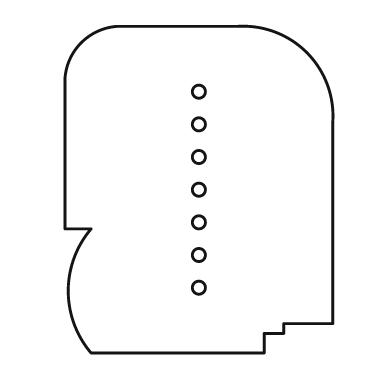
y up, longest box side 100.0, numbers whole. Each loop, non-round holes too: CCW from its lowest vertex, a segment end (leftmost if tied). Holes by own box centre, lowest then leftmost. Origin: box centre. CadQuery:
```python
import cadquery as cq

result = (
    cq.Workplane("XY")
    .moveTo(-33.0, -50.0)
    .lineTo(20.0, -50.0)
    .lineTo(20.0, -44.0)
    .lineTo(26.0, -44.0)
    .lineTo(26.0, -41.0)
    .lineTo(41.0, -41.0)
    .lineTo(41.0, 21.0)
    .threePointArc((33.0, 42.0), (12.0, 50.0))
    .lineTo(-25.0, 50.0)
    .threePointArc((-36.0, 45.0), (-41.0, 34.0))
    .lineTo(-41.0, -12.0)
    .lineTo(-33.0, -12.0)
    .threePointArc((-40.0, -31.0), (-33.0, -50.0))
    .close()
    .moveTo(0.0, -30.0)
    .circle(2.0)
    .moveTo(0.0, -20.0)
    .circle(2.0)
    .moveTo(0.0, -10.0)
    .circle(2.0)
    .moveTo(0.0, 0.0)
    .circle(2.0)
    .moveTo(0.0, 10.0)
    .circle(2.0)
    .moveTo(0.0, 20.0)
    .circle(2.0)
    .moveTo(0.0, 30.0)
    .circle(2.0)
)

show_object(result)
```